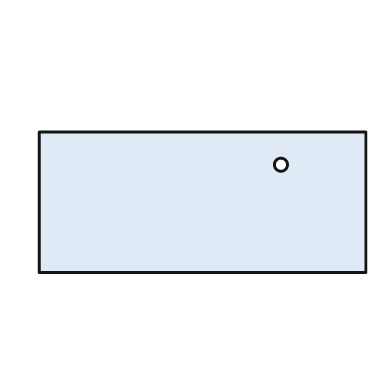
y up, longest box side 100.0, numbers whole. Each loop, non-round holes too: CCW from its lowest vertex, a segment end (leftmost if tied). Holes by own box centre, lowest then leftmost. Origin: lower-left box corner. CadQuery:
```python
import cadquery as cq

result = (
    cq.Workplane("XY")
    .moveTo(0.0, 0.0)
    .lineTo(100.0, 0.0)
    .lineTo(100.0, 43.0)
    .lineTo(0.0, 43.0)
    .close()
    .moveTo(74.0, 33.0)
    .circle(2.0)
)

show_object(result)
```